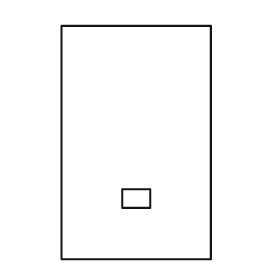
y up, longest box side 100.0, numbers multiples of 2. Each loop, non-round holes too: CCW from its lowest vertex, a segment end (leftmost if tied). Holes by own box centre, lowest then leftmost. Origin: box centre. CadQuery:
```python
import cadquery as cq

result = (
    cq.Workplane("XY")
    .moveTo(-32.0, -50.0)
    .lineTo(32.0, -50.0)
    .lineTo(32.0, 50.0)
    .lineTo(-32.0, 50.0)
    .close()
    .moveTo(-6.0, -28.0)
    .lineTo(6.0, -28.0)
    .lineTo(6.0, -20.0)
    .lineTo(-6.0, -20.0)
    .close()
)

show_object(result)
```